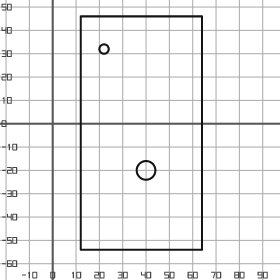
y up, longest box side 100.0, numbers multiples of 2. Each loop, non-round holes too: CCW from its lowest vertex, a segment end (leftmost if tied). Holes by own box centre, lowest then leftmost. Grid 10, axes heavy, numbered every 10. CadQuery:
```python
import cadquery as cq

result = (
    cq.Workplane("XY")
    .moveTo(12.0, -54.0)
    .lineTo(64.0, -54.0)
    .lineTo(64.0, 46.0)
    .lineTo(12.0, 46.0)
    .close()
    .moveTo(40.0, -20.0)
    .circle(4.0)
    .moveTo(22.0, 32.0)
    .circle(2.0)
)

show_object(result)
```